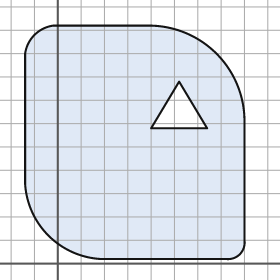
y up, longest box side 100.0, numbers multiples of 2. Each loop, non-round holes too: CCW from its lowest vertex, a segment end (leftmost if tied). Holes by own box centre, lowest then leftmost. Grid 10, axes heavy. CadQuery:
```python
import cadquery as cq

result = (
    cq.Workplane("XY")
    .moveTo(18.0, 2.0)
    .lineTo(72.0, 2.0)
    .threePointArc((78.0, 4.0), (80.0, 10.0))
    .lineTo(80.0, 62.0)
    .threePointArc((68.0, 90.0), (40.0, 102.0))
    .lineTo(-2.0, 102.0)
    .threePointArc((-10.0, 98.0), (-14.0, 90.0))
    .lineTo(-14.0, 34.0)
    .threePointArc((-4.0, 12.0), (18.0, 2.0))
    .close()
    .moveTo(40.0, 58.0)
    .lineTo(64.0, 58.0)
    .lineTo(52.0, 78.0)
    .close()
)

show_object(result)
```